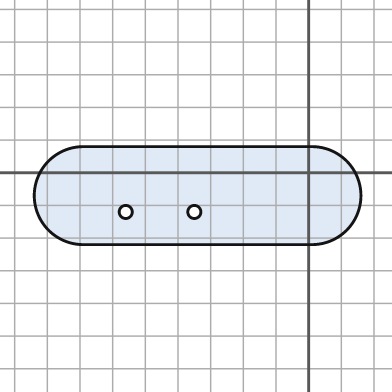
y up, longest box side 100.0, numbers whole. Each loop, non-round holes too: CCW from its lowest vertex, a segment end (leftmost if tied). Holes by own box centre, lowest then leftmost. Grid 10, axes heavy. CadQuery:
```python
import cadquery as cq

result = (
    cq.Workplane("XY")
    .moveTo(-69.0, -22.0)
    .lineTo(1.0, -22.0)
    .threePointArc((16.0, -7.0), (1.0, 8.0))
    .lineTo(-69.0, 8.0)
    .threePointArc((-84.0, -7.0), (-69.0, -22.0))
    .close()
    .moveTo(-56.0, -12.0)
    .circle(2.0)
    .moveTo(-35.0, -12.0)
    .circle(2.0)
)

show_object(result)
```